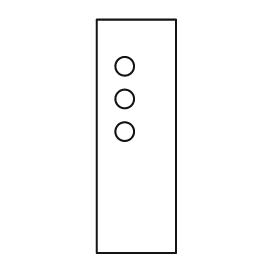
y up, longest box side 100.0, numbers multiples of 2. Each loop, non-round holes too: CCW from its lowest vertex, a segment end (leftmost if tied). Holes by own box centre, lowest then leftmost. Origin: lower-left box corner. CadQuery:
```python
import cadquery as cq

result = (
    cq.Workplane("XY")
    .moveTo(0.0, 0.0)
    .lineTo(34.0, 0.0)
    .lineTo(34.0, 100.0)
    .lineTo(0.0, 100.0)
    .close()
    .moveTo(12.0, 52.0)
    .circle(4.0)
    .moveTo(12.0, 66.0)
    .circle(4.0)
    .moveTo(12.0, 80.0)
    .circle(4.0)
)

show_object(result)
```